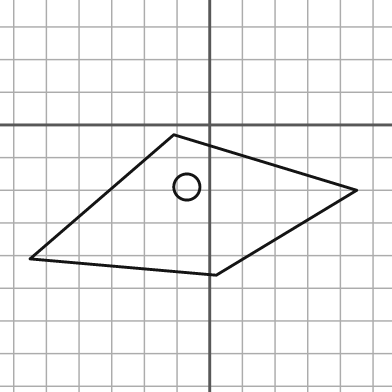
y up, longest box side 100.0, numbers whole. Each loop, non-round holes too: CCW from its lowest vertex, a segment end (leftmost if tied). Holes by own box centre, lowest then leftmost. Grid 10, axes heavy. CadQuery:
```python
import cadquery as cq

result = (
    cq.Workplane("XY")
    .moveTo(2.0, -46.0)
    .lineTo(45.0, -20.0)
    .lineTo(-11.0, -3.0)
    .lineTo(-55.0, -41.0)
    .close()
    .moveTo(-7.0, -19.0)
    .circle(4.0)
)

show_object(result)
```